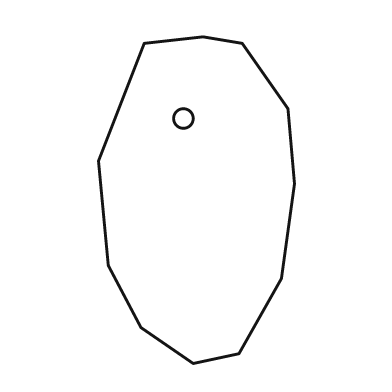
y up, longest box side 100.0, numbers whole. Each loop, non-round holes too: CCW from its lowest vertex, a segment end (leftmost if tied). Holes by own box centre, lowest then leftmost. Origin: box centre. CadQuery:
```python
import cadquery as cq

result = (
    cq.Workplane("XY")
    .moveTo(-1.0, -50.0)
    .lineTo(13.0, -47.0)
    .lineTo(26.0, -24.0)
    .lineTo(30.0, 5.0)
    .lineTo(28.0, 28.0)
    .lineTo(14.0, 48.0)
    .lineTo(2.0, 50.0)
    .lineTo(-16.0, 48.0)
    .lineTo(-30.0, 12.0)
    .lineTo(-27.0, -20.0)
    .lineTo(-17.0, -39.0)
    .close()
    .moveTo(-4.0, 25.0)
    .circle(3.0)
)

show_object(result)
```